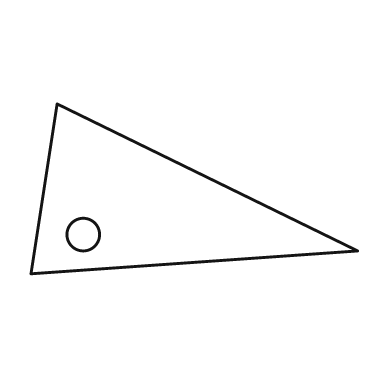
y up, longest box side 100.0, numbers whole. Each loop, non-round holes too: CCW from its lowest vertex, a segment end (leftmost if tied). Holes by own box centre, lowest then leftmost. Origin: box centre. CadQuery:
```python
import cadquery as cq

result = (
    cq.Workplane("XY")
    .moveTo(-50.0, -26.0)
    .lineTo(50.0, -19.0)
    .lineTo(-42.0, 26.0)
    .close()
    .moveTo(-34.0, -14.0)
    .circle(5.0)
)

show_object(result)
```